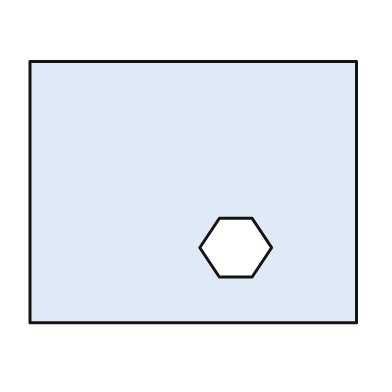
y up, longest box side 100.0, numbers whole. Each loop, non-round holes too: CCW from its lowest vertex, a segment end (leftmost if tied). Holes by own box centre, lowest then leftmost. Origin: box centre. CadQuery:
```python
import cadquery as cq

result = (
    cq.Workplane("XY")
    .moveTo(-50.0, -40.0)
    .lineTo(50.0, -40.0)
    .lineTo(50.0, 40.0)
    .lineTo(-50.0, 40.0)
    .close()
    .moveTo(8.0, -26.0)
    .lineTo(18.0, -26.0)
    .lineTo(24.0, -17.0)
    .lineTo(18.0, -8.0)
    .lineTo(8.0, -8.0)
    .lineTo(2.0, -17.0)
    .close()
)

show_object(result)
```